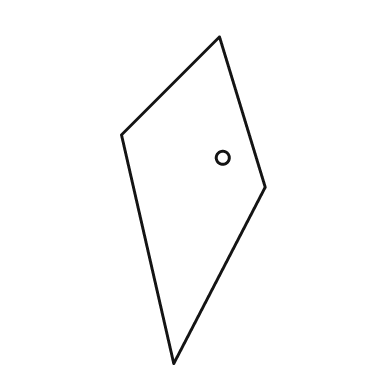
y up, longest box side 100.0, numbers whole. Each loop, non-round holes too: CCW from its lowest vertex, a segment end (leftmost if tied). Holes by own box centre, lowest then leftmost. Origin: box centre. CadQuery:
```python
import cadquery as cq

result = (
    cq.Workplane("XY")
    .moveTo(-6.0, -50.0)
    .lineTo(22.0, 4.0)
    .lineTo(8.0, 50.0)
    .lineTo(-22.0, 20.0)
    .close()
    .moveTo(9.0, 13.0)
    .circle(2.0)
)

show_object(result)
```